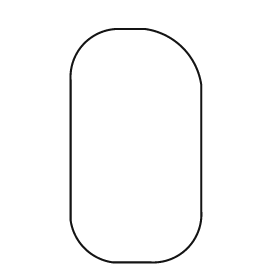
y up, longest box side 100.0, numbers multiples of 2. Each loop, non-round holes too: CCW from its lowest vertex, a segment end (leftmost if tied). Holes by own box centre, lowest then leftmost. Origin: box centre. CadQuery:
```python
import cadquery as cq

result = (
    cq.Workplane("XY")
    .moveTo(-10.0, -50.0)
    .lineTo(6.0, -50.0)
    .threePointArc((22.0, -44.0), (28.0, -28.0))
    .lineTo(28.0, 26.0)
    .threePointArc((20.0, 42.0), (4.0, 50.0))
    .lineTo(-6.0, 50.0)
    .threePointArc((-22.0, 44.0), (-28.0, 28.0))
    .lineTo(-28.0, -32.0)
    .threePointArc((-22.0, -44.0), (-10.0, -50.0))
    .close()
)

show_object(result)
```